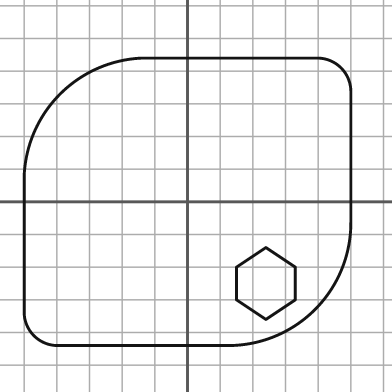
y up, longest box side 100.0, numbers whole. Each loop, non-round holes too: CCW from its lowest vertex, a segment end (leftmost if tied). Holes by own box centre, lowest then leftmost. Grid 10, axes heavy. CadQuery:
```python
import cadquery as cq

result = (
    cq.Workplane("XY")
    .moveTo(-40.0, -44.0)
    .lineTo(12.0, -44.0)
    .threePointArc((39.0, -33.0), (50.0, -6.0))
    .lineTo(50.0, 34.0)
    .threePointArc((47.0, 41.0), (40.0, 44.0))
    .lineTo(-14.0, 44.0)
    .threePointArc((-39.0, 33.0), (-50.0, 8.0))
    .lineTo(-50.0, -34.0)
    .threePointArc((-47.0, -41.0), (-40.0, -44.0))
    .close()
    .moveTo(24.0, -36.0)
    .lineTo(33.0, -30.0)
    .lineTo(33.0, -20.0)
    .lineTo(24.0, -14.0)
    .lineTo(15.0, -20.0)
    .lineTo(15.0, -30.0)
    .close()
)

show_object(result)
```